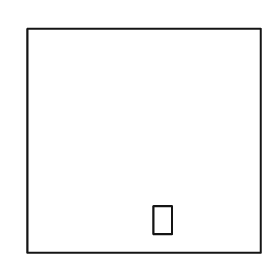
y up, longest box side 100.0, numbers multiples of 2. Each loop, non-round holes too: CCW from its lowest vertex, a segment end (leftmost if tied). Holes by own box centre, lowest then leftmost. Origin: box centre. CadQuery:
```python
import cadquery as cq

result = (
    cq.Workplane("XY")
    .moveTo(-50.0, -48.0)
    .lineTo(50.0, -48.0)
    .lineTo(50.0, 48.0)
    .lineTo(-50.0, 48.0)
    .close()
    .moveTo(4.0, -40.0)
    .lineTo(12.0, -40.0)
    .lineTo(12.0, -28.0)
    .lineTo(4.0, -28.0)
    .close()
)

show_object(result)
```